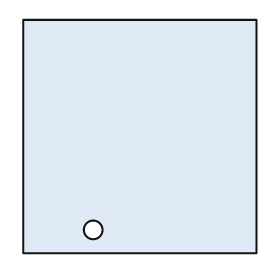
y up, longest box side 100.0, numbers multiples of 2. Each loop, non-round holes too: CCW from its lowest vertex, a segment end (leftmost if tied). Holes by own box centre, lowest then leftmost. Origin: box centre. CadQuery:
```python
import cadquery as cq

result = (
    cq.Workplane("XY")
    .moveTo(-50.0, -50.0)
    .lineTo(50.0, -50.0)
    .lineTo(50.0, 50.0)
    .lineTo(-50.0, 50.0)
    .close()
    .moveTo(-20.0, -40.0)
    .circle(4.0)
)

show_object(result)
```